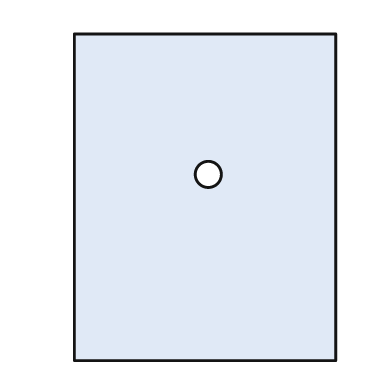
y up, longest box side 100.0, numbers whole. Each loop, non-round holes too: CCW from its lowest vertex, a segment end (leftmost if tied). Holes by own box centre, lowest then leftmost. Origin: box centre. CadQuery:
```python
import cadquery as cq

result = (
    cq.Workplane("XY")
    .moveTo(-40.0, -50.0)
    .lineTo(40.0, -50.0)
    .lineTo(40.0, 50.0)
    .lineTo(-40.0, 50.0)
    .close()
    .moveTo(1.0, 7.0)
    .circle(4.0)
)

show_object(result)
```